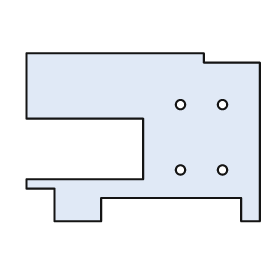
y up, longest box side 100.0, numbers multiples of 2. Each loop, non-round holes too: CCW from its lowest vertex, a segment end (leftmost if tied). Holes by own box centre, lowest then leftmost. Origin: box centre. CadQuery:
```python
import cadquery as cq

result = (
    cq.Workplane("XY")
    .moveTo(-38.0, -36.0)
    .lineTo(-18.0, -36.0)
    .lineTo(-18.0, -26.0)
    .lineTo(42.0, -26.0)
    .lineTo(42.0, -36.0)
    .lineTo(50.0, -36.0)
    .lineTo(50.0, 32.0)
    .lineTo(26.0, 32.0)
    .lineTo(26.0, 36.0)
    .lineTo(-50.0, 36.0)
    .lineTo(-50.0, 8.0)
    .lineTo(0.0, 8.0)
    .lineTo(0.0, -18.0)
    .lineTo(-50.0, -18.0)
    .lineTo(-50.0, -22.0)
    .lineTo(-38.0, -22.0)
    .close()
    .moveTo(16.0, -14.0)
    .circle(2.0)
    .moveTo(34.0, -14.0)
    .circle(2.0)
    .moveTo(16.0, 14.0)
    .circle(2.0)
    .moveTo(34.0, 14.0)
    .circle(2.0)
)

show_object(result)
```